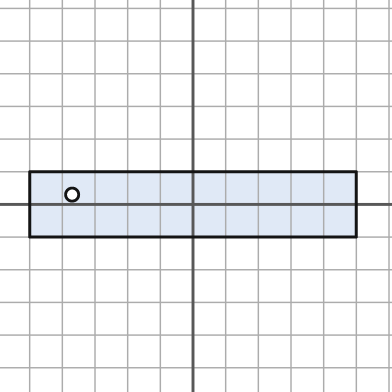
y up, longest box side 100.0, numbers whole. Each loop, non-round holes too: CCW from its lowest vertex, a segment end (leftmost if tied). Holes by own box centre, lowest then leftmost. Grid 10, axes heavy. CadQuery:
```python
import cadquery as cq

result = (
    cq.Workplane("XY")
    .moveTo(-50.0, -10.0)
    .lineTo(50.0, -10.0)
    .lineTo(50.0, 10.0)
    .lineTo(-50.0, 10.0)
    .close()
    .moveTo(-37.0, 3.0)
    .circle(2.0)
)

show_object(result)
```